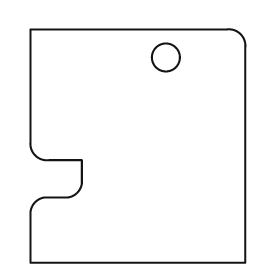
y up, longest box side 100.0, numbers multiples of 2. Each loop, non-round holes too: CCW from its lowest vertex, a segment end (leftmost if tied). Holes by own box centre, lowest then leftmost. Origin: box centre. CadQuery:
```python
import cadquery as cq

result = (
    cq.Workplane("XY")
    .moveTo(-46.0, -50.0)
    .lineTo(46.0, -50.0)
    .lineTo(46.0, 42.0)
    .threePointArc((44.0, 48.0), (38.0, 50.0))
    .lineTo(-46.0, 50.0)
    .lineTo(-46.0, 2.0)
    .threePointArc((-44.0, -4.0), (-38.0, -6.0))
    .lineTo(-24.0, -6.0)
    .lineTo(-24.0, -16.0)
    .threePointArc((-26.0, -20.0), (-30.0, -22.0))
    .lineTo(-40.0, -22.0)
    .threePointArc((-44.0, -24.0), (-46.0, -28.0))
    .close()
    .moveTo(12.0, 38.0)
    .circle(6.0)
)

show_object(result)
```